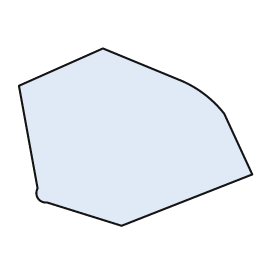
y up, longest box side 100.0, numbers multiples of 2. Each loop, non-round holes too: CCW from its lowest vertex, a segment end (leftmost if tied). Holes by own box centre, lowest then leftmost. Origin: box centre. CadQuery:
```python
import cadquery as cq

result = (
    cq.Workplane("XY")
    .moveTo(-6.0, -38.0)
    .lineTo(50.0, -16.0)
    .lineTo(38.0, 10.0)
    .threePointArc((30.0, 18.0), (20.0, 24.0))
    .lineTo(-14.0, 38.0)
    .lineTo(-50.0, 22.0)
    .lineTo(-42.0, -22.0)
    .threePointArc((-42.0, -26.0), (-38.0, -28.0))
    .close()
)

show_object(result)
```